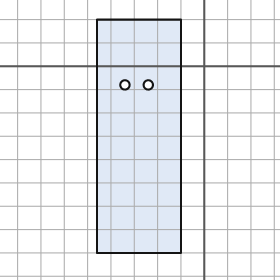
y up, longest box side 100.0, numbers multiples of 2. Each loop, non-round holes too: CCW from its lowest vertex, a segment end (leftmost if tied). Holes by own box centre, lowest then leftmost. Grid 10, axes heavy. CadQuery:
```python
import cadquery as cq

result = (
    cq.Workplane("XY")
    .moveTo(-46.0, -80.0)
    .lineTo(-10.0, -80.0)
    .lineTo(-10.0, 20.0)
    .lineTo(-46.0, 20.0)
    .close()
    .moveTo(-34.0, -8.0)
    .circle(2.0)
    .moveTo(-24.0, -8.0)
    .circle(2.0)
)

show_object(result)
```